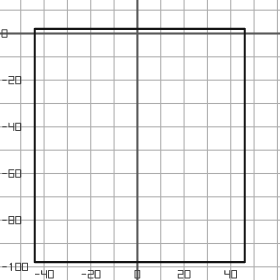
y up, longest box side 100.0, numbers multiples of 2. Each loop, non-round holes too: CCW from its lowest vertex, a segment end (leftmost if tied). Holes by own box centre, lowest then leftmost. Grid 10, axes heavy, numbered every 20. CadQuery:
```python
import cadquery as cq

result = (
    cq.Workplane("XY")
    .moveTo(-44.0, -98.0)
    .lineTo(46.0, -98.0)
    .lineTo(46.0, 2.0)
    .lineTo(-44.0, 2.0)
    .close()
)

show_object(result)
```